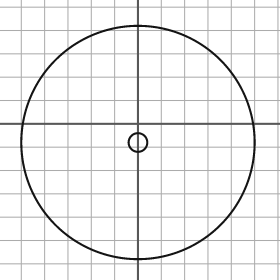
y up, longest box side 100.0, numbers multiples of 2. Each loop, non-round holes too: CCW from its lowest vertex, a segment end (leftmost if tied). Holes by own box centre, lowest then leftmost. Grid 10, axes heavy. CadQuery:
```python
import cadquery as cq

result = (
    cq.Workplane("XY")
    .moveTo(0.0, -8.0)
    .circle(50.0)
    .moveTo(0.0, -8.0)
    .circle(4.0)
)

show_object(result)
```